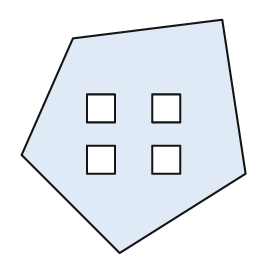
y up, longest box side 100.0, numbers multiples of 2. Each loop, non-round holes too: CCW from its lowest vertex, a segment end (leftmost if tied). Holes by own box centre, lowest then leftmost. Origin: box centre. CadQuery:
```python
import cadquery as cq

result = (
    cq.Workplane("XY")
    .moveTo(-6.0, -50.0)
    .lineTo(48.0, -16.0)
    .lineTo(38.0, 50.0)
    .lineTo(-26.0, 42.0)
    .lineTo(-48.0, -8.0)
    .close()
    .moveTo(-20.0, -16.0)
    .lineTo(-8.0, -16.0)
    .lineTo(-8.0, -4.0)
    .lineTo(-20.0, -4.0)
    .close()
    .moveTo(8.0, -16.0)
    .lineTo(20.0, -16.0)
    .lineTo(20.0, -4.0)
    .lineTo(8.0, -4.0)
    .close()
    .moveTo(-20.0, 6.0)
    .lineTo(-8.0, 6.0)
    .lineTo(-8.0, 18.0)
    .lineTo(-20.0, 18.0)
    .close()
    .moveTo(8.0, 6.0)
    .lineTo(20.0, 6.0)
    .lineTo(20.0, 18.0)
    .lineTo(8.0, 18.0)
    .close()
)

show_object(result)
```